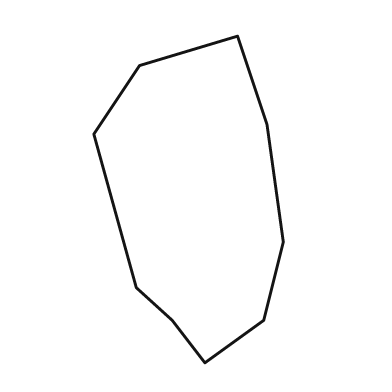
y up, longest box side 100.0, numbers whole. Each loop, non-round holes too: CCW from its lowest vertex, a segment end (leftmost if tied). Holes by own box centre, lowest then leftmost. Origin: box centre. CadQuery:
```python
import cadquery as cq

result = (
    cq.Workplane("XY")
    .moveTo(5.0, -50.0)
    .lineTo(23.0, -37.0)
    .lineTo(29.0, -13.0)
    .lineTo(24.0, 23.0)
    .lineTo(15.0, 50.0)
    .lineTo(-15.0, 41.0)
    .lineTo(-29.0, 20.0)
    .lineTo(-16.0, -27.0)
    .lineTo(-5.0, -37.0)
    .close()
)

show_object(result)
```